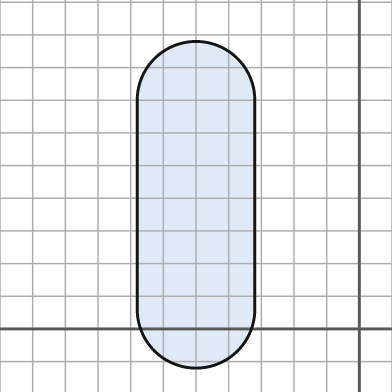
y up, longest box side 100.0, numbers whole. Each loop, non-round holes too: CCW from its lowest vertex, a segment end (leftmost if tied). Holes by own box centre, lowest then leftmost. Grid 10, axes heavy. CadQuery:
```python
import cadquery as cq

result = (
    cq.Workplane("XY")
    .moveTo(-68.0, 6.0)
    .threePointArc((-50.0, -12.0), (-32.0, 6.0))
    .lineTo(-32.0, 70.0)
    .threePointArc((-50.0, 88.0), (-68.0, 70.0))
    .close()
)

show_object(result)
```